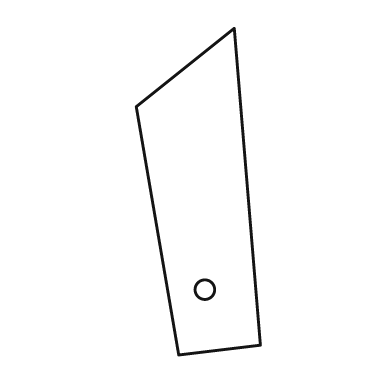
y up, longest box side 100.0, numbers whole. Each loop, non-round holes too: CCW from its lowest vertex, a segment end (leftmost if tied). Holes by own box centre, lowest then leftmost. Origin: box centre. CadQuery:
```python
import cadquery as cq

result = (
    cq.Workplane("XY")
    .moveTo(-6.0, -50.0)
    .lineTo(19.0, -47.0)
    .lineTo(11.0, 50.0)
    .lineTo(-19.0, 26.0)
    .close()
    .moveTo(2.0, -30.0)
    .circle(3.0)
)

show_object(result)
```